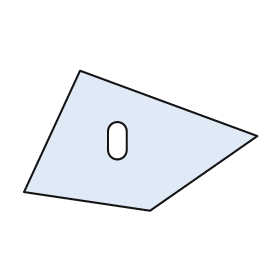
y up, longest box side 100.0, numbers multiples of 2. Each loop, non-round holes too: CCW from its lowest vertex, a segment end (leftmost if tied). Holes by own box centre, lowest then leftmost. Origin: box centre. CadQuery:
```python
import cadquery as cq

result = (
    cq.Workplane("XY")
    .moveTo(4.0, -30.0)
    .lineTo(50.0, 2.0)
    .lineTo(-26.0, 30.0)
    .lineTo(-50.0, -22.0)
    .close()
    .moveTo(-14.0, -4.0)
    .threePointArc((-10.0, -8.0), (-6.0, -4.0))
    .lineTo(-6.0, 4.0)
    .threePointArc((-10.0, 8.0), (-14.0, 4.0))
    .close()
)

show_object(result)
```